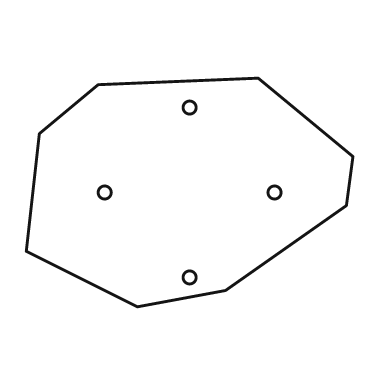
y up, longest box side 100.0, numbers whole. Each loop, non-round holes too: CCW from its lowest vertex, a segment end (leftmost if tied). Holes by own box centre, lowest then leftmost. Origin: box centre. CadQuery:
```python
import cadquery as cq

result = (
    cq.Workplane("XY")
    .moveTo(-16.0, -35.0)
    .lineTo(11.0, -30.0)
    .lineTo(48.0, -4.0)
    .lineTo(50.0, 11.0)
    .lineTo(21.0, 35.0)
    .lineTo(-28.0, 33.0)
    .lineTo(-46.0, 18.0)
    .lineTo(-50.0, -18.0)
    .close()
    .moveTo(0.0, -26.0)
    .circle(2.0)
    .moveTo(-26.0, 0.0)
    .circle(2.0)
    .moveTo(26.0, 0.0)
    .circle(2.0)
    .moveTo(0.0, 26.0)
    .circle(2.0)
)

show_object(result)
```